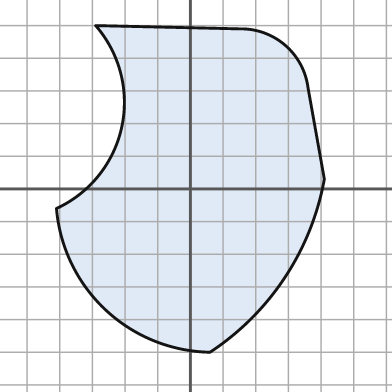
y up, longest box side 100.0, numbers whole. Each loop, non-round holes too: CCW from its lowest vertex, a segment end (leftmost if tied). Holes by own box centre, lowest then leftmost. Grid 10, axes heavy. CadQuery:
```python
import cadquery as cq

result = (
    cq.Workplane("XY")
    .moveTo(6.0, -50.0)
    .threePointArc((29.0, -27.0), (41.0, 3.0))
    .lineTo(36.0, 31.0)
    .threePointArc((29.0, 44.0), (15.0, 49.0))
    .lineTo(-29.0, 50.0)
    .threePointArc((-21.0, 19.0), (-41.0, -6.0))
    .threePointArc((-26.0, -37.0), (6.0, -50.0))
    .close()
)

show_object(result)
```